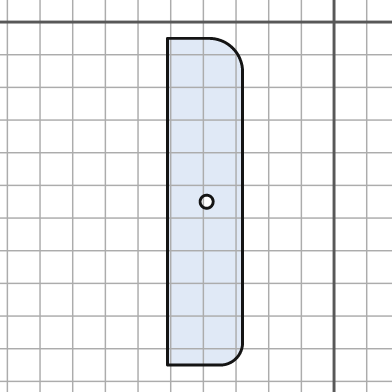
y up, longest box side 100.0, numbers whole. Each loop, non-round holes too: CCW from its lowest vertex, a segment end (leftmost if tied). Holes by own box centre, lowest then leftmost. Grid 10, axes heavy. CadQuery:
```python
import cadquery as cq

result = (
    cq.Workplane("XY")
    .moveTo(-51.0, -105.0)
    .lineTo(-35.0, -105.0)
    .threePointArc((-30.0, -103.0), (-28.0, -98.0))
    .lineTo(-28.0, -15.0)
    .threePointArc((-31.0, -8.0), (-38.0, -5.0))
    .lineTo(-51.0, -5.0)
    .close()
    .moveTo(-39.0, -55.0)
    .circle(2.0)
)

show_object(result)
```